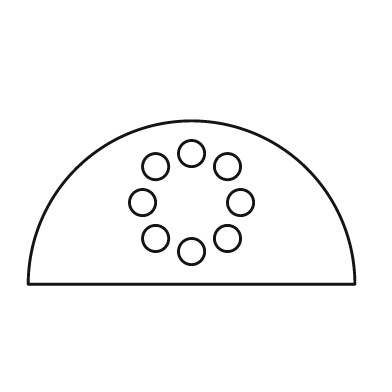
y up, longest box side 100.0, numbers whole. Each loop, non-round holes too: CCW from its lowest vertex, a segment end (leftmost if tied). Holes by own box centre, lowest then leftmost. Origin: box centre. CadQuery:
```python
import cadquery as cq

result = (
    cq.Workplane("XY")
    .moveTo(-50.0, -25.0)
    .lineTo(50.0, -25.0)
    .threePointArc((0.0, 25.0), (-50.0, -25.0))
    .close()
    .moveTo(0.0, -15.0)
    .circle(4.0)
    .moveTo(-11.0, -11.0)
    .circle(4.0)
    .moveTo(11.0, -11.0)
    .circle(4.0)
    .moveTo(-15.0, 0.0)
    .circle(4.0)
    .moveTo(15.0, 0.0)
    .circle(4.0)
    .moveTo(-11.0, 11.0)
    .circle(4.0)
    .moveTo(11.0, 11.0)
    .circle(4.0)
    .moveTo(0.0, 15.0)
    .circle(4.0)
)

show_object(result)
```